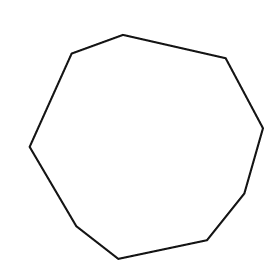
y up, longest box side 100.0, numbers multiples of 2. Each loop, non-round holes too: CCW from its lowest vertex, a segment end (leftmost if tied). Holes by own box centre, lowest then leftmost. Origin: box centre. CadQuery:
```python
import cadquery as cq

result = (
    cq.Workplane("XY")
    .moveTo(-12.0, -48.0)
    .lineTo(26.0, -40.0)
    .lineTo(42.0, -20.0)
    .lineTo(50.0, 8.0)
    .lineTo(34.0, 38.0)
    .lineTo(-10.0, 48.0)
    .lineTo(-32.0, 40.0)
    .lineTo(-50.0, 0.0)
    .lineTo(-30.0, -34.0)
    .close()
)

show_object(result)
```